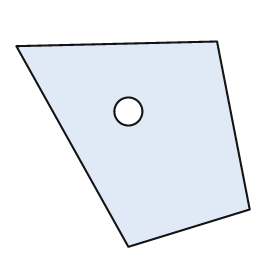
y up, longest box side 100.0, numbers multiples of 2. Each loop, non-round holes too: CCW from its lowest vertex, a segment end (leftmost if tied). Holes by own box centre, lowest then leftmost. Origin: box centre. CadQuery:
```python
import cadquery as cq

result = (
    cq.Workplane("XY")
    .moveTo(-2.0, -44.0)
    .lineTo(50.0, -28.0)
    .lineTo(36.0, 44.0)
    .lineTo(-50.0, 42.0)
    .close()
    .moveTo(-2.0, 14.0)
    .circle(6.0)
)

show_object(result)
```